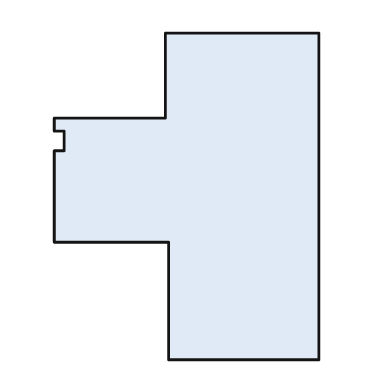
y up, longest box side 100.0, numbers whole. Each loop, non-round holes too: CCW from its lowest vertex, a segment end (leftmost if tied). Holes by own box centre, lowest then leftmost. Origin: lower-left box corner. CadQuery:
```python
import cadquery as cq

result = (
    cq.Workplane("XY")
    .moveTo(35.0, 0.0)
    .lineTo(81.0, 0.0)
    .lineTo(81.0, 100.0)
    .lineTo(34.0, 100.0)
    .lineTo(34.0, 74.0)
    .lineTo(0.0, 74.0)
    .lineTo(0.0, 70.0)
    .lineTo(3.0, 70.0)
    .lineTo(3.0, 64.0)
    .lineTo(0.0, 64.0)
    .lineTo(0.0, 36.0)
    .lineTo(35.0, 36.0)
    .close()
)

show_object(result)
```